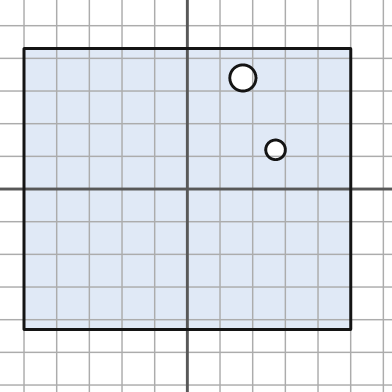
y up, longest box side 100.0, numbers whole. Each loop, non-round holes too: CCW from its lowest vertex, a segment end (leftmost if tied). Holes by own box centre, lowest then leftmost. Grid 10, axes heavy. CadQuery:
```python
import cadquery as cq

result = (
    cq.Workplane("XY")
    .moveTo(-50.0, -43.0)
    .lineTo(50.0, -43.0)
    .lineTo(50.0, 43.0)
    .lineTo(-50.0, 43.0)
    .close()
    .moveTo(27.0, 12.0)
    .circle(3.0)
    .moveTo(17.0, 34.0)
    .circle(4.0)
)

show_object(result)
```